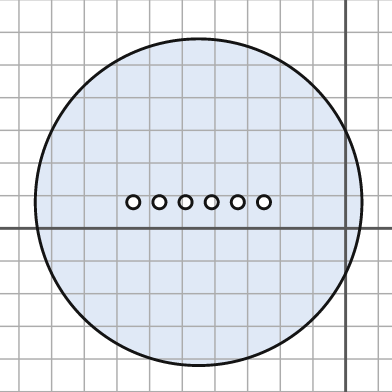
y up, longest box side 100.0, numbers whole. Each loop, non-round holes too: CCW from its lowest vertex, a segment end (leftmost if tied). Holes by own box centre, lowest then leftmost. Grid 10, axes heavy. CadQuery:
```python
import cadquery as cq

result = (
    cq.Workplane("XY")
    .moveTo(-45.0, 8.0)
    .circle(50.0)
    .moveTo(-65.0, 8.0)
    .circle(2.0)
    .moveTo(-57.0, 8.0)
    .circle(2.0)
    .moveTo(-49.0, 8.0)
    .circle(2.0)
    .moveTo(-41.0, 8.0)
    .circle(2.0)
    .moveTo(-33.0, 8.0)
    .circle(2.0)
    .moveTo(-25.0, 8.0)
    .circle(2.0)
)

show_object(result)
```